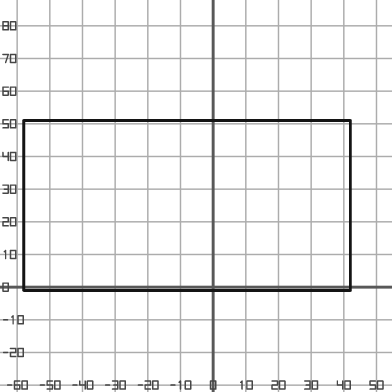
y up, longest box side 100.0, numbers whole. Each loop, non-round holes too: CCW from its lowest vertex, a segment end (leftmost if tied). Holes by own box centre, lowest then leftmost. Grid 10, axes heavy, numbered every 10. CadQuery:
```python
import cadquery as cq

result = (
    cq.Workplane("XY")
    .moveTo(-58.0, -1.0)
    .lineTo(42.0, -1.0)
    .lineTo(42.0, 51.0)
    .lineTo(-58.0, 51.0)
    .close()
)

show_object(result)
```